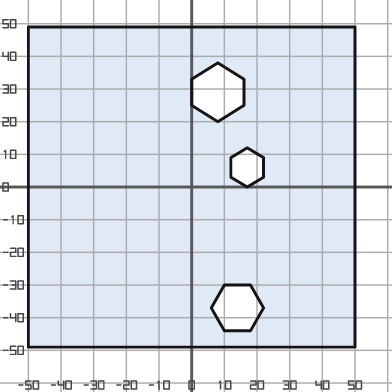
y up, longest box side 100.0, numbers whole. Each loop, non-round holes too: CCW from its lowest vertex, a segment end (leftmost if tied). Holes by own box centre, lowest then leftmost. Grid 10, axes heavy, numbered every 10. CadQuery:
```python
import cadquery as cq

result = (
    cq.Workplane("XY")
    .moveTo(-50.0, -49.0)
    .lineTo(50.0, -49.0)
    .lineTo(50.0, 49.0)
    .lineTo(-50.0, 49.0)
    .close()
    .moveTo(10.0, -44.0)
    .lineTo(18.0, -44.0)
    .lineTo(22.0, -37.0)
    .lineTo(18.0, -30.0)
    .lineTo(10.0, -30.0)
    .lineTo(6.0, -37.0)
    .close()
    .moveTo(17.0, 0.0)
    .lineTo(22.0, 3.0)
    .lineTo(22.0, 9.0)
    .lineTo(17.0, 12.0)
    .lineTo(12.0, 9.0)
    .lineTo(12.0, 3.0)
    .close()
    .moveTo(8.0, 20.0)
    .lineTo(16.0, 25.0)
    .lineTo(16.0, 33.0)
    .lineTo(8.0, 38.0)
    .lineTo(0.0, 33.0)
    .lineTo(0.0, 25.0)
    .close()
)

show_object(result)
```